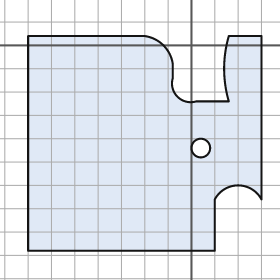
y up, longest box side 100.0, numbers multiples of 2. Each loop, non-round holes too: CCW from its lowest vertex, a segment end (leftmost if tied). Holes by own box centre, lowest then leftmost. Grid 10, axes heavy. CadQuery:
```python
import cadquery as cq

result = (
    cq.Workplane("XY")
    .moveTo(-70.0, -88.0)
    .lineTo(10.0, -88.0)
    .lineTo(10.0, -66.0)
    .threePointArc((20.0, -60.0), (30.0, -66.0))
    .lineTo(30.0, 4.0)
    .lineTo(16.0, 4.0)
    .threePointArc((14.0, -10.0), (16.0, -24.0))
    .lineTo(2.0, -24.0)
    .threePointArc((-6.0, -22.0), (-8.0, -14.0))
    .lineTo(-8.0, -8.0)
    .threePointArc((-12.0, 0.0), (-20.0, 4.0))
    .lineTo(-70.0, 4.0)
    .close()
    .moveTo(4.0, -44.0)
    .circle(4.0)
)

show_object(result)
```